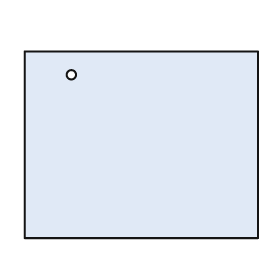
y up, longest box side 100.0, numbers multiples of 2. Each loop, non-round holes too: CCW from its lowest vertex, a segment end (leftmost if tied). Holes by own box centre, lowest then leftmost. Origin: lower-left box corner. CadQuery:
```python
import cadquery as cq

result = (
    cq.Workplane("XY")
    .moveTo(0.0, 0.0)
    .lineTo(100.0, 0.0)
    .lineTo(100.0, 80.0)
    .lineTo(0.0, 80.0)
    .close()
    .moveTo(20.0, 70.0)
    .circle(2.0)
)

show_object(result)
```